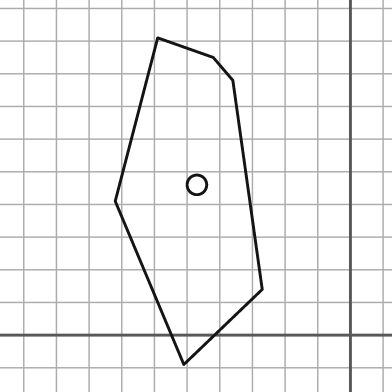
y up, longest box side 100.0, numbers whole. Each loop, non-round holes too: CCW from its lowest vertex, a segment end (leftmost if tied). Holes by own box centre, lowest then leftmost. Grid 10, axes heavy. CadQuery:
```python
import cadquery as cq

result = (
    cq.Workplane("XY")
    .moveTo(-51.0, -9.0)
    .lineTo(-27.0, 14.0)
    .lineTo(-36.0, 78.0)
    .lineTo(-42.0, 85.0)
    .lineTo(-59.0, 91.0)
    .lineTo(-72.0, 41.0)
    .close()
    .moveTo(-47.0, 46.0)
    .circle(3.0)
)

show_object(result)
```